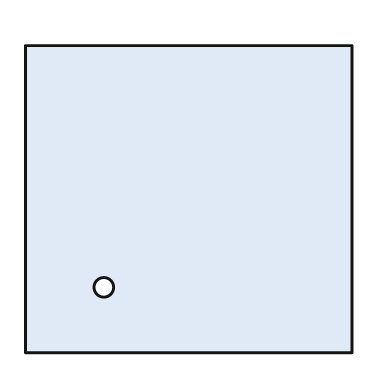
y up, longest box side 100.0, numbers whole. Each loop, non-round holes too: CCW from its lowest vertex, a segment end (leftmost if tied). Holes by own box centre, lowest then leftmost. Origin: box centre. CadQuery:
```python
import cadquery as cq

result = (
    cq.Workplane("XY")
    .moveTo(-50.0, -47.0)
    .lineTo(50.0, -47.0)
    .lineTo(50.0, 47.0)
    .lineTo(-50.0, 47.0)
    .close()
    .moveTo(-26.0, -27.0)
    .circle(3.0)
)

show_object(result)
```